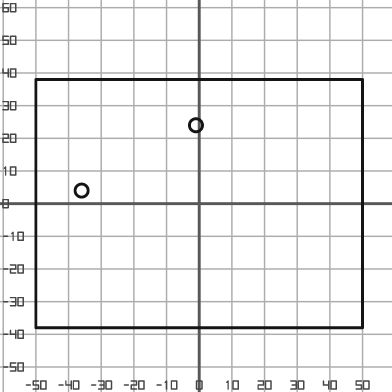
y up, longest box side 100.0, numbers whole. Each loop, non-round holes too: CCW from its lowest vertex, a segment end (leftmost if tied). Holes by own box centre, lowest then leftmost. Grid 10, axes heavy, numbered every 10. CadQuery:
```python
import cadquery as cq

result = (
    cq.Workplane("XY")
    .moveTo(-50.0, -38.0)
    .lineTo(50.0, -38.0)
    .lineTo(50.0, 38.0)
    .lineTo(-50.0, 38.0)
    .close()
    .moveTo(-36.0, 4.0)
    .circle(2.0)
    .moveTo(-1.0, 24.0)
    .circle(2.0)
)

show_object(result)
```